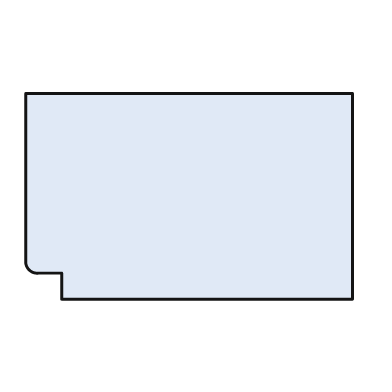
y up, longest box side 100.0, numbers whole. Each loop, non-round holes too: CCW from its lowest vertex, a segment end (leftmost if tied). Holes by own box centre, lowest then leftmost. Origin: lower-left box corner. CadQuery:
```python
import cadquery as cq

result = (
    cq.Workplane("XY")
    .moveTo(11.0, 0.0)
    .lineTo(100.0, 0.0)
    .lineTo(100.0, 63.0)
    .lineTo(0.0, 63.0)
    .lineTo(0.0, 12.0)
    .threePointArc((1.0, 9.0), (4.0, 8.0))
    .lineTo(11.0, 8.0)
    .close()
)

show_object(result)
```